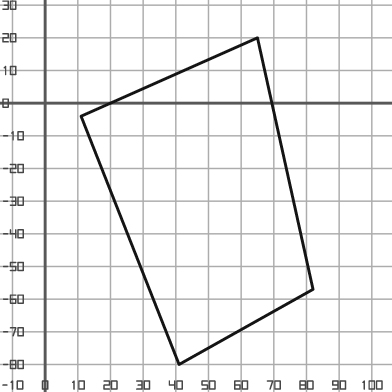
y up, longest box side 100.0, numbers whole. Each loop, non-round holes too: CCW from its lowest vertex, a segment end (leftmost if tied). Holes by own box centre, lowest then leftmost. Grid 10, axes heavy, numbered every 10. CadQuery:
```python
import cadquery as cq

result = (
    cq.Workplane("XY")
    .moveTo(41.0, -80.0)
    .lineTo(82.0, -57.0)
    .lineTo(65.0, 20.0)
    .lineTo(11.0, -4.0)
    .close()
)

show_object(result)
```